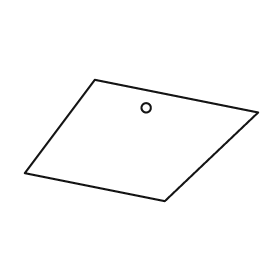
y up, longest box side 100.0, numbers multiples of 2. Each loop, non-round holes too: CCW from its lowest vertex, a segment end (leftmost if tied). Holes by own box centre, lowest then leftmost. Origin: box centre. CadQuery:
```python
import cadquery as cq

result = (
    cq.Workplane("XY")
    .moveTo(10.0, -26.0)
    .lineTo(50.0, 12.0)
    .lineTo(-20.0, 26.0)
    .lineTo(-50.0, -14.0)
    .close()
    .moveTo(2.0, 14.0)
    .circle(2.0)
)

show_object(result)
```